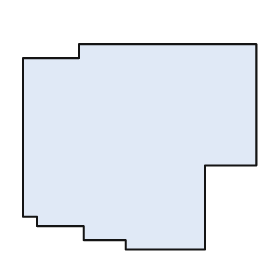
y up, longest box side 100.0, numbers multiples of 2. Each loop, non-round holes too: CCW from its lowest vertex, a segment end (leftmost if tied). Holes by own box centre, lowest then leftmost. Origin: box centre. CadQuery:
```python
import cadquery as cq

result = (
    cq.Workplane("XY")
    .moveTo(-6.0, -44.0)
    .lineTo(28.0, -44.0)
    .lineTo(28.0, -8.0)
    .lineTo(50.0, -8.0)
    .lineTo(50.0, 44.0)
    .lineTo(-26.0, 44.0)
    .lineTo(-26.0, 38.0)
    .lineTo(-50.0, 38.0)
    .lineTo(-50.0, -30.0)
    .lineTo(-44.0, -30.0)
    .lineTo(-44.0, -34.0)
    .lineTo(-24.0, -34.0)
    .lineTo(-24.0, -40.0)
    .lineTo(-6.0, -40.0)
    .close()
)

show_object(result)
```